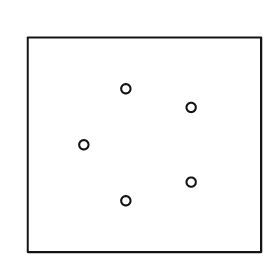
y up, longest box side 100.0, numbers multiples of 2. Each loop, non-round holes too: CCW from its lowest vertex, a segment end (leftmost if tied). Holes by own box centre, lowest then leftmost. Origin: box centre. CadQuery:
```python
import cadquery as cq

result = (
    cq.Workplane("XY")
    .moveTo(-50.0, -46.0)
    .lineTo(50.0, -46.0)
    .lineTo(50.0, 46.0)
    .lineTo(-50.0, 46.0)
    .close()
    .moveTo(-8.0, -24.0)
    .circle(2.0)
    .moveTo(20.0, -16.0)
    .circle(2.0)
    .moveTo(-26.0, 0.0)
    .circle(2.0)
    .moveTo(20.0, 16.0)
    .circle(2.0)
    .moveTo(-8.0, 24.0)
    .circle(2.0)
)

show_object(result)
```